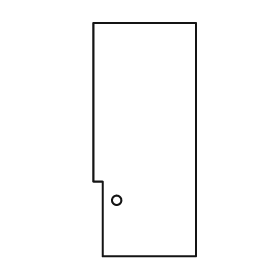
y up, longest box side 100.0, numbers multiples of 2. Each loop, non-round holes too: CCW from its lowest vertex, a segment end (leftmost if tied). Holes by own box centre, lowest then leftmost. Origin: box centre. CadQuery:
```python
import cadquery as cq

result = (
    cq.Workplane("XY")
    .moveTo(-18.0, -50.0)
    .lineTo(22.0, -50.0)
    .lineTo(22.0, 50.0)
    .lineTo(-22.0, 50.0)
    .lineTo(-22.0, -18.0)
    .lineTo(-18.0, -18.0)
    .close()
    .moveTo(-12.0, -26.0)
    .circle(2.0)
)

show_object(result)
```